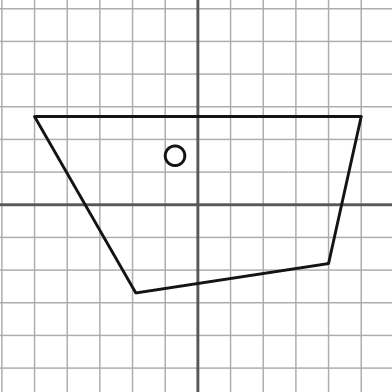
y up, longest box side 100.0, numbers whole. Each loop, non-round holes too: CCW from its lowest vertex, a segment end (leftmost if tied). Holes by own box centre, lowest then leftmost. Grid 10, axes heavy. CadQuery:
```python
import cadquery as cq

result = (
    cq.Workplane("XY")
    .moveTo(-19.0, -27.0)
    .lineTo(40.0, -18.0)
    .lineTo(50.0, 27.0)
    .lineTo(-50.0, 27.0)
    .close()
    .moveTo(-7.0, 15.0)
    .circle(3.0)
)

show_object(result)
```